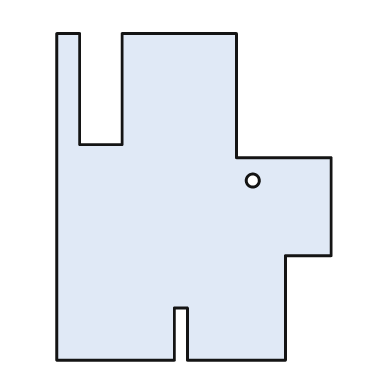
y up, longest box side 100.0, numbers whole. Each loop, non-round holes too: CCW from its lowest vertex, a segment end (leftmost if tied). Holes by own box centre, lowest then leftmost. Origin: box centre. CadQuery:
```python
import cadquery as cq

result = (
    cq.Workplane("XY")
    .moveTo(-42.0, -50.0)
    .lineTo(-6.0, -50.0)
    .lineTo(-6.0, -34.0)
    .lineTo(-2.0, -34.0)
    .lineTo(-2.0, -50.0)
    .lineTo(28.0, -50.0)
    .lineTo(28.0, -18.0)
    .lineTo(42.0, -18.0)
    .lineTo(42.0, 12.0)
    .lineTo(13.0, 12.0)
    .lineTo(13.0, 50.0)
    .lineTo(-22.0, 50.0)
    .lineTo(-22.0, 16.0)
    .lineTo(-35.0, 16.0)
    .lineTo(-35.0, 50.0)
    .lineTo(-42.0, 50.0)
    .close()
    .moveTo(18.0, 5.0)
    .circle(2.0)
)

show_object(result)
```